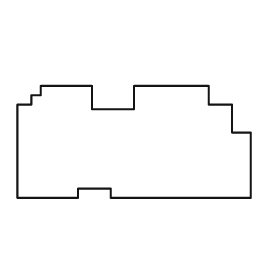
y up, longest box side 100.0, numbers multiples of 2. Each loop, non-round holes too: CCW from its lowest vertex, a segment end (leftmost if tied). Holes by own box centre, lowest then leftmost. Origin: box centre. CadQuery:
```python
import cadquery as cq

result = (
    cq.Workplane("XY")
    .moveTo(-50.0, -24.0)
    .lineTo(-24.0, -24.0)
    .lineTo(-24.0, -20.0)
    .lineTo(-10.0, -20.0)
    .lineTo(-10.0, -24.0)
    .lineTo(50.0, -24.0)
    .lineTo(50.0, 4.0)
    .lineTo(42.0, 4.0)
    .lineTo(42.0, 16.0)
    .lineTo(32.0, 16.0)
    .lineTo(32.0, 24.0)
    .lineTo(0.0, 24.0)
    .lineTo(0.0, 14.0)
    .lineTo(-18.0, 14.0)
    .lineTo(-18.0, 24.0)
    .lineTo(-40.0, 24.0)
    .lineTo(-40.0, 20.0)
    .lineTo(-44.0, 20.0)
    .lineTo(-44.0, 16.0)
    .lineTo(-50.0, 16.0)
    .close()
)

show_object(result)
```